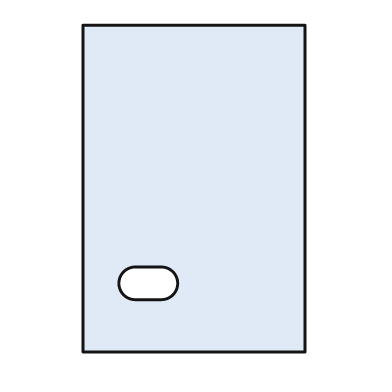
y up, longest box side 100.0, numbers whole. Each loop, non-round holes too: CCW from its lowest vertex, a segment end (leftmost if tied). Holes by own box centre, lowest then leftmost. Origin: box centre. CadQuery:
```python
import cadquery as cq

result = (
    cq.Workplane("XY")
    .moveTo(-34.0, -50.0)
    .lineTo(34.0, -50.0)
    .lineTo(34.0, 50.0)
    .lineTo(-34.0, 50.0)
    .close()
    .moveTo(-18.0, -34.0)
    .lineTo(-10.0, -34.0)
    .threePointArc((-5.0, -29.0), (-10.0, -24.0))
    .lineTo(-18.0, -24.0)
    .threePointArc((-23.0, -29.0), (-18.0, -34.0))
    .close()
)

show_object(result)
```